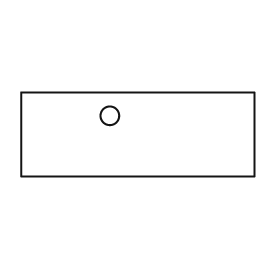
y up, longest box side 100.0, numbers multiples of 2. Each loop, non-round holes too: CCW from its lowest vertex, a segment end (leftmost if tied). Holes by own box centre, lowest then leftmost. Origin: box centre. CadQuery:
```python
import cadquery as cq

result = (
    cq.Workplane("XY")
    .moveTo(-50.0, -18.0)
    .lineTo(50.0, -18.0)
    .lineTo(50.0, 18.0)
    .lineTo(-50.0, 18.0)
    .close()
    .moveTo(-12.0, 8.0)
    .circle(4.0)
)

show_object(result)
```